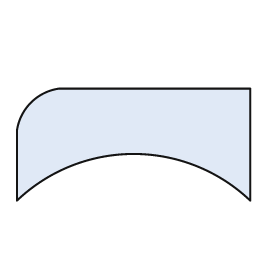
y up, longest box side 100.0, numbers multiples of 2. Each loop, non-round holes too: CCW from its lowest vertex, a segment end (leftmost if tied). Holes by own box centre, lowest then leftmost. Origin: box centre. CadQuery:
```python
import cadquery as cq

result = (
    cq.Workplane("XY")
    .moveTo(-50.0, -24.0)
    .threePointArc((0.0, -4.0), (50.0, -24.0))
    .lineTo(50.0, 24.0)
    .lineTo(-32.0, 24.0)
    .threePointArc((-44.0, 18.0), (-50.0, 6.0))
    .close()
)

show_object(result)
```